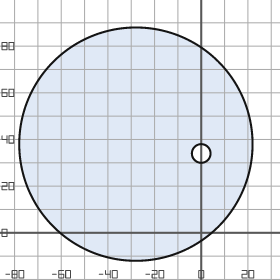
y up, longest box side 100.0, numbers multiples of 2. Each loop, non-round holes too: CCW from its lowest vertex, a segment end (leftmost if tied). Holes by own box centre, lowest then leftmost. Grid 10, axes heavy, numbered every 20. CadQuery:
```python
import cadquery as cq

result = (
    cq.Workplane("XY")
    .moveTo(-28.0, 38.0)
    .circle(50.0)
    .moveTo(0.0, 34.0)
    .circle(4.0)
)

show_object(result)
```